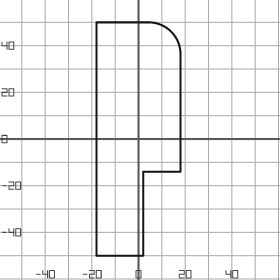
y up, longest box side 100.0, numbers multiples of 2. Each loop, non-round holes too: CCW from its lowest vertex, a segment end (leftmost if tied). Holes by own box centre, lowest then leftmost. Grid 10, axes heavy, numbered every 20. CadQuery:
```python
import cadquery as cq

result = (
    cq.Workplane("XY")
    .moveTo(-18.0, -50.0)
    .lineTo(2.0, -50.0)
    .lineTo(2.0, -14.0)
    .lineTo(18.0, -14.0)
    .lineTo(18.0, 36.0)
    .threePointArc((14.0, 46.0), (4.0, 50.0))
    .lineTo(-18.0, 50.0)
    .close()
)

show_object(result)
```